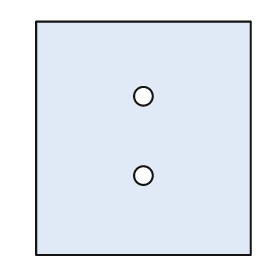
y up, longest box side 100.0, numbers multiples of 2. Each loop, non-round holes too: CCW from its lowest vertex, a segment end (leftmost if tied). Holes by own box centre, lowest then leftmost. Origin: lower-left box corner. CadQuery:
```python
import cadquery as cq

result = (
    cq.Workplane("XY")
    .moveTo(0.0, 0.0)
    .lineTo(92.0, 0.0)
    .lineTo(92.0, 100.0)
    .lineTo(0.0, 100.0)
    .close()
    .moveTo(46.0, 34.0)
    .circle(4.0)
    .moveTo(46.0, 68.0)
    .circle(4.0)
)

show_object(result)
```